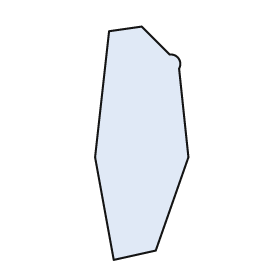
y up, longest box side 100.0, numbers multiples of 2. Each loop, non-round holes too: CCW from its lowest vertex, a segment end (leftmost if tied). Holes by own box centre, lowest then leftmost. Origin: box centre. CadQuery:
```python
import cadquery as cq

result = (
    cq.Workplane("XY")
    .moveTo(-12.0, -50.0)
    .lineTo(6.0, -46.0)
    .lineTo(20.0, -6.0)
    .lineTo(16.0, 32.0)
    .threePointArc((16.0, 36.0), (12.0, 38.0))
    .lineTo(0.0, 50.0)
    .lineTo(-14.0, 48.0)
    .lineTo(-20.0, -6.0)
    .close()
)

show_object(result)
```